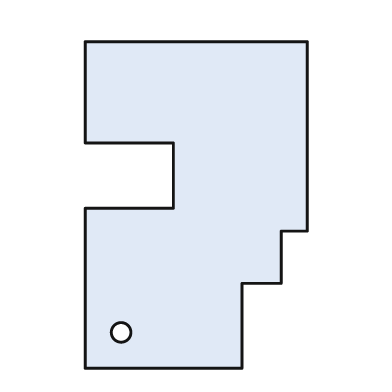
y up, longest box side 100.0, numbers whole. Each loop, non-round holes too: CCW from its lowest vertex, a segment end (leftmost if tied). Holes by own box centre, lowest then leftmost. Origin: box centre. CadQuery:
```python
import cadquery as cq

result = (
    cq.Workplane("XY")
    .moveTo(-34.0, -50.0)
    .lineTo(14.0, -50.0)
    .lineTo(14.0, -24.0)
    .lineTo(26.0, -24.0)
    .lineTo(26.0, -8.0)
    .lineTo(34.0, -8.0)
    .lineTo(34.0, 50.0)
    .lineTo(-34.0, 50.0)
    .lineTo(-34.0, 19.0)
    .lineTo(-7.0, 19.0)
    .lineTo(-7.0, -1.0)
    .lineTo(-34.0, -1.0)
    .close()
    .moveTo(-23.0, -39.0)
    .circle(3.0)
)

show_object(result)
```